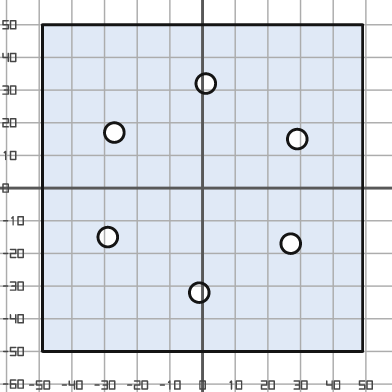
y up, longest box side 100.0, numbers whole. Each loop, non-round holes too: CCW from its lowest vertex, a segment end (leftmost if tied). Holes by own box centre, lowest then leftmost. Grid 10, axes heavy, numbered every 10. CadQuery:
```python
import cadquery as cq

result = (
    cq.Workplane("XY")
    .moveTo(-49.0, -50.0)
    .lineTo(49.0, -50.0)
    .lineTo(49.0, 50.0)
    .lineTo(-49.0, 50.0)
    .close()
    .moveTo(-1.0, -32.0)
    .circle(3.0)
    .moveTo(27.0, -17.0)
    .circle(3.0)
    .moveTo(-29.0, -15.0)
    .circle(3.0)
    .moveTo(29.0, 15.0)
    .circle(3.0)
    .moveTo(-27.0, 17.0)
    .circle(3.0)
    .moveTo(1.0, 32.0)
    .circle(3.0)
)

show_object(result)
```